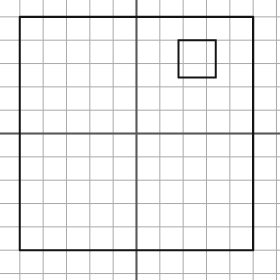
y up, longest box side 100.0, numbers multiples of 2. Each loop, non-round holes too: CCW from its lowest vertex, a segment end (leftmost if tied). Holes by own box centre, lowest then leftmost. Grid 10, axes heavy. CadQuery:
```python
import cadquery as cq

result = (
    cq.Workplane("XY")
    .moveTo(-50.0, -50.0)
    .lineTo(50.0, -50.0)
    .lineTo(50.0, 50.0)
    .lineTo(-50.0, 50.0)
    .close()
    .moveTo(18.0, 24.0)
    .lineTo(34.0, 24.0)
    .lineTo(34.0, 40.0)
    .lineTo(18.0, 40.0)
    .close()
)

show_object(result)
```